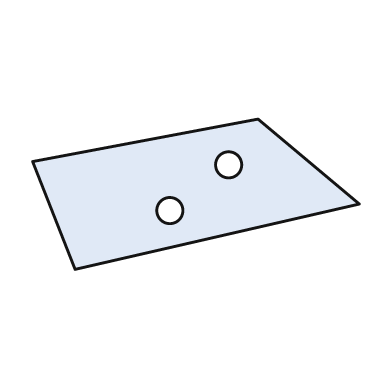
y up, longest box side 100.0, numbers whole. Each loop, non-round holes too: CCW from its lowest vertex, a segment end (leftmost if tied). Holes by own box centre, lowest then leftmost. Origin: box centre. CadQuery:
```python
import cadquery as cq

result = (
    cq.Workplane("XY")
    .moveTo(-37.0, -23.0)
    .lineTo(50.0, -3.0)
    .lineTo(19.0, 23.0)
    .lineTo(-50.0, 10.0)
    .close()
    .moveTo(-8.0, -5.0)
    .circle(4.0)
    .moveTo(10.0, 9.0)
    .circle(4.0)
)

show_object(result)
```